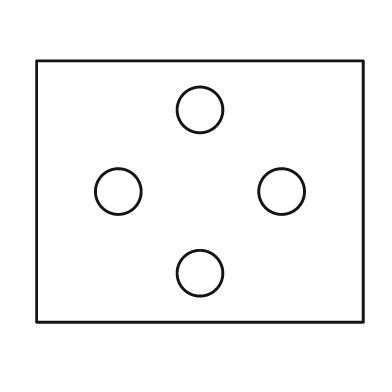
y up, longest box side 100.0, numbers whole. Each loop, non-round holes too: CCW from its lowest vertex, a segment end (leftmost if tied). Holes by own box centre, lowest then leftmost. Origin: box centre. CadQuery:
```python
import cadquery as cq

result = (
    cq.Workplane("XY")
    .moveTo(-50.0, -40.0)
    .lineTo(50.0, -40.0)
    .lineTo(50.0, 40.0)
    .lineTo(-50.0, 40.0)
    .close()
    .moveTo(0.0, -25.0)
    .circle(7.0)
    .moveTo(-25.0, 0.0)
    .circle(7.0)
    .moveTo(25.0, 0.0)
    .circle(7.0)
    .moveTo(0.0, 25.0)
    .circle(7.0)
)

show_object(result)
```